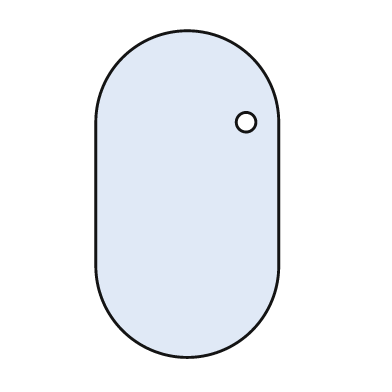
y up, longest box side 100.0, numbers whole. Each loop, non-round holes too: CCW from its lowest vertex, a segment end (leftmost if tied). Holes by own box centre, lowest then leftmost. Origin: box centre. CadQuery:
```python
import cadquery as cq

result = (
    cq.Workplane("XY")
    .moveTo(-28.0, -22.0)
    .threePointArc((0.0, -50.0), (28.0, -22.0))
    .lineTo(28.0, 22.0)
    .threePointArc((0.0, 50.0), (-28.0, 22.0))
    .close()
    .moveTo(18.0, 22.0)
    .circle(3.0)
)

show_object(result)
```